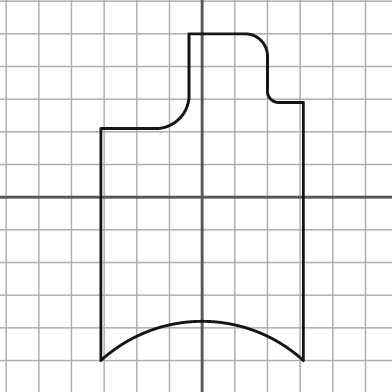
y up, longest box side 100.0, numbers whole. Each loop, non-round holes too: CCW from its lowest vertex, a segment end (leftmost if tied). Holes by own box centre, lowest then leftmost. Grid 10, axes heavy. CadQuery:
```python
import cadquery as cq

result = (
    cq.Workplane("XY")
    .moveTo(-31.0, -50.0)
    .threePointArc((0.0, -38.0), (31.0, -50.0))
    .lineTo(31.0, 29.0)
    .lineTo(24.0, 29.0)
    .threePointArc((21.0, 30.0), (20.0, 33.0))
    .lineTo(20.0, 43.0)
    .threePointArc((18.0, 48.0), (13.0, 50.0))
    .lineTo(-4.0, 50.0)
    .lineTo(-4.0, 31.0)
    .threePointArc((-7.0, 24.0), (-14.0, 21.0))
    .lineTo(-31.0, 21.0)
    .close()
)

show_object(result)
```